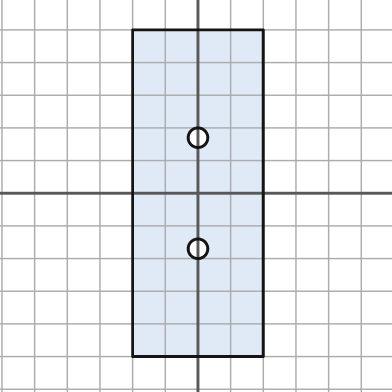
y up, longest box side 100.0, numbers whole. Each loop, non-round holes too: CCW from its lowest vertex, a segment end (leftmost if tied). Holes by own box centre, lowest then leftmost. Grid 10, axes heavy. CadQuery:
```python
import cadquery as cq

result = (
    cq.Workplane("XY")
    .moveTo(-20.0, -50.0)
    .lineTo(20.0, -50.0)
    .lineTo(20.0, 50.0)
    .lineTo(-20.0, 50.0)
    .close()
    .moveTo(0.0, -17.0)
    .circle(3.0)
    .moveTo(0.0, 17.0)
    .circle(3.0)
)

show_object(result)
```